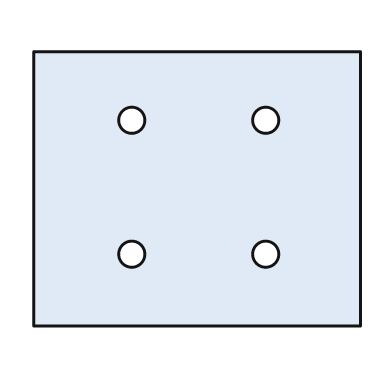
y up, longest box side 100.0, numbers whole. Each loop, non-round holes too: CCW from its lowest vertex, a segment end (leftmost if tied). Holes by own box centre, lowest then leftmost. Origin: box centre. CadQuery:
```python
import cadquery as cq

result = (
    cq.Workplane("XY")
    .moveTo(-50.0, -42.0)
    .lineTo(50.0, -42.0)
    .lineTo(50.0, 42.0)
    .lineTo(-50.0, 42.0)
    .close()
    .moveTo(-20.0, -20.0)
    .circle(4.0)
    .moveTo(21.0, -20.0)
    .circle(4.0)
    .moveTo(-20.0, 21.0)
    .circle(4.0)
    .moveTo(21.0, 21.0)
    .circle(4.0)
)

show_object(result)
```